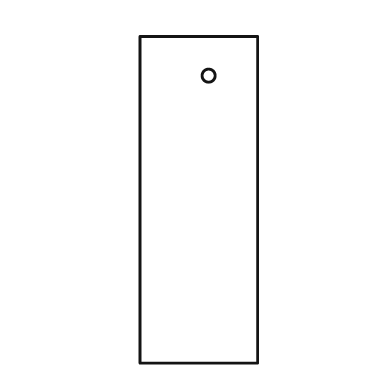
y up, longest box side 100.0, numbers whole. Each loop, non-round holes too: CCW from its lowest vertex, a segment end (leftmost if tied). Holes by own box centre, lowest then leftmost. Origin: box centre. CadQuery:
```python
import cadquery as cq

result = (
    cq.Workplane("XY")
    .moveTo(-18.0, -50.0)
    .lineTo(18.0, -50.0)
    .lineTo(18.0, 50.0)
    .lineTo(-18.0, 50.0)
    .close()
    .moveTo(3.0, 38.0)
    .circle(2.0)
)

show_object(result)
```